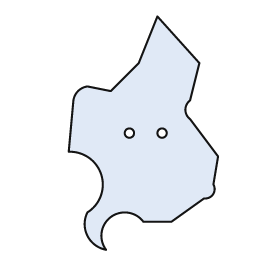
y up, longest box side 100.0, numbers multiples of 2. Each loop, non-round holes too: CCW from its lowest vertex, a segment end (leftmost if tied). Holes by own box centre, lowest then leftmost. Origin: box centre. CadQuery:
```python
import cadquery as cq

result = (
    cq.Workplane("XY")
    .moveTo(-16.0, -50.0)
    .threePointArc((-14.0, -36.0), (0.0, -38.0))
    .lineTo(12.0, -38.0)
    .lineTo(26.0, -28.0)
    .threePointArc((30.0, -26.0), (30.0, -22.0))
    .lineTo(32.0, -10.0)
    .lineTo(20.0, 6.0)
    .threePointArc((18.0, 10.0), (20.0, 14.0))
    .lineTo(24.0, 30.0)
    .lineTo(6.0, 50.0)
    .lineTo(-2.0, 30.0)
    .lineTo(-14.0, 18.0)
    .lineTo(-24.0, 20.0)
    .threePointArc((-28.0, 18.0), (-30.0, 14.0))
    .lineTo(-32.0, -8.0)
    .threePointArc((-18.0, -18.0), (-24.0, -34.0))
    .threePointArc((-24.0, -44.0), (-16.0, -50.0))
    .close()
    .moveTo(-6.0, 0.0)
    .circle(2.0)
    .moveTo(8.0, 0.0)
    .circle(2.0)
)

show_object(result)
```